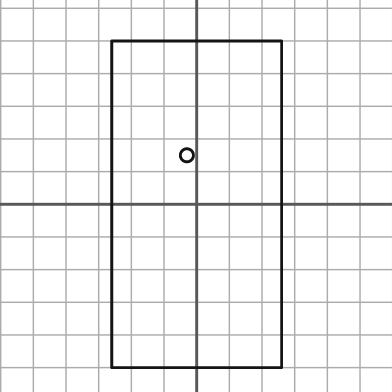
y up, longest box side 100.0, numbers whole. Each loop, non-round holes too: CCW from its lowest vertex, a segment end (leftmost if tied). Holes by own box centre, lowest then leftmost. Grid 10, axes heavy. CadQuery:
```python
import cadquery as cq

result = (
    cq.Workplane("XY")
    .moveTo(-26.0, -50.0)
    .lineTo(26.0, -50.0)
    .lineTo(26.0, 50.0)
    .lineTo(-26.0, 50.0)
    .close()
    .moveTo(-3.0, 15.0)
    .circle(2.0)
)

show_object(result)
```